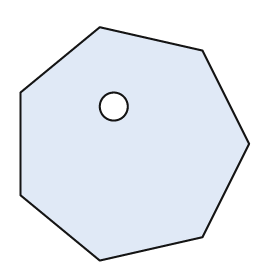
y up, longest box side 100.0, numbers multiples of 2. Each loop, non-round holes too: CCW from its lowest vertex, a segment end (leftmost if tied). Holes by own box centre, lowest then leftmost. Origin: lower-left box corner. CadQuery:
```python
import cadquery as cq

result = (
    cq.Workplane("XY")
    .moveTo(34.0, 0.0)
    .lineTo(78.0, 10.0)
    .lineTo(98.0, 50.0)
    .lineTo(78.0, 90.0)
    .lineTo(34.0, 100.0)
    .lineTo(0.0, 72.0)
    .lineTo(0.0, 28.0)
    .close()
    .moveTo(40.0, 66.0)
    .circle(6.0)
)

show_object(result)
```